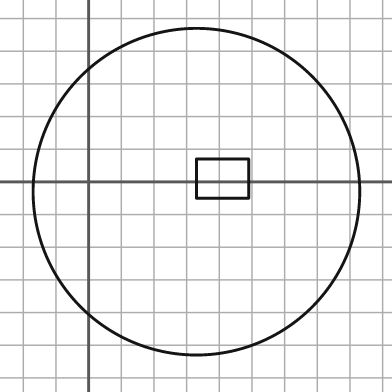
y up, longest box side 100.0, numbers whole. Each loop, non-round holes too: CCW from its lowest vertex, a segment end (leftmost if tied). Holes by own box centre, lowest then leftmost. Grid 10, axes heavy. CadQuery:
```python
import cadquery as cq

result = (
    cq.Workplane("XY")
    .moveTo(33.0, -3.0)
    .circle(50.0)
    .moveTo(33.0, -5.0)
    .lineTo(49.0, -5.0)
    .lineTo(49.0, 7.0)
    .lineTo(33.0, 7.0)
    .close()
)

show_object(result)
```